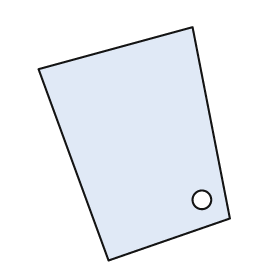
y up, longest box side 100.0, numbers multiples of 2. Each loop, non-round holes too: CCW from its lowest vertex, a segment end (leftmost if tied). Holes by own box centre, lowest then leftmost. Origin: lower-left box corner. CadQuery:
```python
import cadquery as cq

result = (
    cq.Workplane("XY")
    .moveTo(30.0, 0.0)
    .lineTo(82.0, 18.0)
    .lineTo(66.0, 100.0)
    .lineTo(0.0, 82.0)
    .close()
    .moveTo(70.0, 26.0)
    .circle(4.0)
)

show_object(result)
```